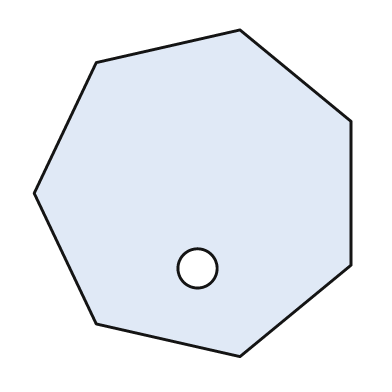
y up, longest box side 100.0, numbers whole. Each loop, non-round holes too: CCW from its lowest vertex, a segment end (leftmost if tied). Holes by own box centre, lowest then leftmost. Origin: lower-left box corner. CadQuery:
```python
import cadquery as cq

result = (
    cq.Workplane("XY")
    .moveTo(63.0, 0.0)
    .lineTo(97.0, 28.0)
    .lineTo(97.0, 72.0)
    .lineTo(63.0, 100.0)
    .lineTo(19.0, 90.0)
    .lineTo(0.0, 50.0)
    .lineTo(19.0, 10.0)
    .close()
    .moveTo(50.0, 27.0)
    .circle(6.0)
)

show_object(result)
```